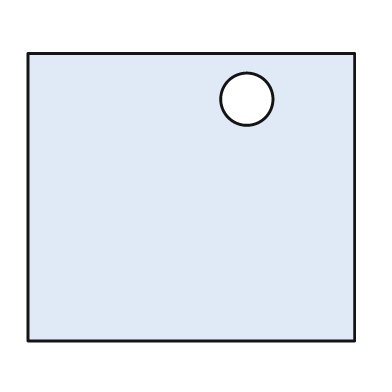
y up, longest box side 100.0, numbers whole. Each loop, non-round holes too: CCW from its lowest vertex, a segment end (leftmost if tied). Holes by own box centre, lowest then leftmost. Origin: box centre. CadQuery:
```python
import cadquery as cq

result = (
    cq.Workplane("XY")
    .moveTo(-50.0, -44.0)
    .lineTo(50.0, -44.0)
    .lineTo(50.0, 44.0)
    .lineTo(-50.0, 44.0)
    .close()
    .moveTo(17.0, 30.0)
    .circle(8.0)
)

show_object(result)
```